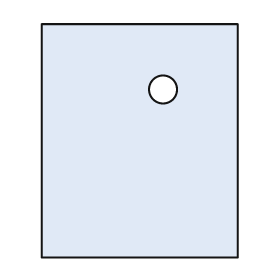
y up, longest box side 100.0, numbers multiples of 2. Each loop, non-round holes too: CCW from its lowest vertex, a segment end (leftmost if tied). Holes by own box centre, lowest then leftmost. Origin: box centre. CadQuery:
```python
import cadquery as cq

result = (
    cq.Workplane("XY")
    .moveTo(-42.0, -50.0)
    .lineTo(42.0, -50.0)
    .lineTo(42.0, 50.0)
    .lineTo(-42.0, 50.0)
    .close()
    .moveTo(10.0, 22.0)
    .circle(6.0)
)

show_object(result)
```